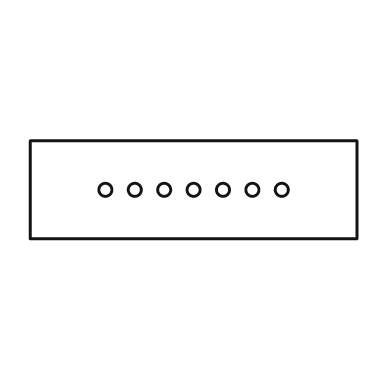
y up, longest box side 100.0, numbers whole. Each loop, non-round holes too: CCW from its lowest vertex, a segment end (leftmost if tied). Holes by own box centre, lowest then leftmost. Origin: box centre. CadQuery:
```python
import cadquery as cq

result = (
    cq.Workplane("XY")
    .moveTo(-50.0, -15.0)
    .lineTo(50.0, -15.0)
    .lineTo(50.0, 15.0)
    .lineTo(-50.0, 15.0)
    .close()
    .moveTo(-27.0, 0.0)
    .circle(2.0)
    .moveTo(-18.0, 0.0)
    .circle(2.0)
    .moveTo(-9.0, 0.0)
    .circle(2.0)
    .moveTo(0.0, 0.0)
    .circle(2.0)
    .moveTo(9.0, 0.0)
    .circle(2.0)
    .moveTo(18.0, 0.0)
    .circle(2.0)
    .moveTo(27.0, 0.0)
    .circle(2.0)
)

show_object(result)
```